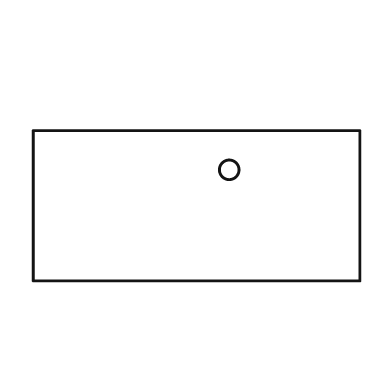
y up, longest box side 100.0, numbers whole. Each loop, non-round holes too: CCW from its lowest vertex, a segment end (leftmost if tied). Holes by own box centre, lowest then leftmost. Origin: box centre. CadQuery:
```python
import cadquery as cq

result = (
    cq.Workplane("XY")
    .moveTo(-50.0, -23.0)
    .lineTo(50.0, -23.0)
    .lineTo(50.0, 23.0)
    .lineTo(-50.0, 23.0)
    .close()
    .moveTo(10.0, 11.0)
    .circle(3.0)
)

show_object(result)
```